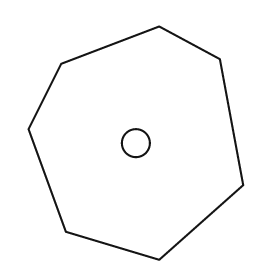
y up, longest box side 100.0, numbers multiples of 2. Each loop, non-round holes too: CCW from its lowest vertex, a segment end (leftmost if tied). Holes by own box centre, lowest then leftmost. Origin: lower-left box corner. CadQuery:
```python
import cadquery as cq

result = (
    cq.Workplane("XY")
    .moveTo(56.0, 0.0)
    .lineTo(92.0, 32.0)
    .lineTo(82.0, 86.0)
    .lineTo(56.0, 100.0)
    .lineTo(14.0, 84.0)
    .lineTo(0.0, 56.0)
    .lineTo(16.0, 12.0)
    .close()
    .moveTo(46.0, 50.0)
    .circle(6.0)
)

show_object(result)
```